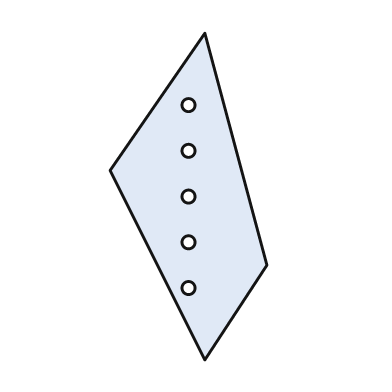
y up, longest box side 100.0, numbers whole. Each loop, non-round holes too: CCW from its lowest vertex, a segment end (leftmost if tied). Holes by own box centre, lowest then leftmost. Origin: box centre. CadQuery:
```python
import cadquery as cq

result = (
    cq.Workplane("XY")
    .moveTo(5.0, -50.0)
    .lineTo(24.0, -21.0)
    .lineTo(5.0, 50.0)
    .lineTo(-24.0, 8.0)
    .close()
    .moveTo(0.0, -28.0)
    .circle(2.0)
    .moveTo(0.0, -14.0)
    .circle(2.0)
    .moveTo(0.0, 0.0)
    .circle(2.0)
    .moveTo(0.0, 14.0)
    .circle(2.0)
    .moveTo(0.0, 28.0)
    .circle(2.0)
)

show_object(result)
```